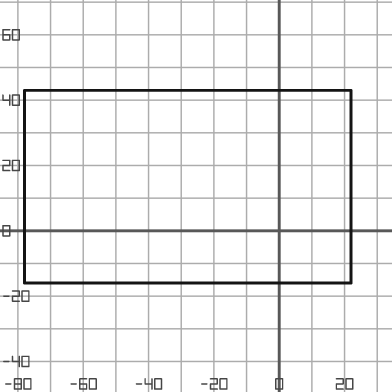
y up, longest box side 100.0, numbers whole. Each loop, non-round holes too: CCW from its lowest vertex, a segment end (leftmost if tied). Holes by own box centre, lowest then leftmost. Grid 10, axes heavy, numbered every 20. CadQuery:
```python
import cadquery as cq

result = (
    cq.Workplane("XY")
    .moveTo(-78.0, -16.0)
    .lineTo(22.0, -16.0)
    .lineTo(22.0, 43.0)
    .lineTo(-78.0, 43.0)
    .close()
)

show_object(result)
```